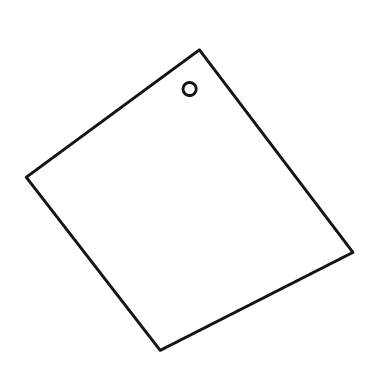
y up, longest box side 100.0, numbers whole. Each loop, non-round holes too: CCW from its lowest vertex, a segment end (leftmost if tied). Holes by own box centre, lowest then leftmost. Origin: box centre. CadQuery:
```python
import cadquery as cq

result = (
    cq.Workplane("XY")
    .moveTo(-9.0, -46.0)
    .lineTo(50.0, -16.0)
    .lineTo(3.0, 46.0)
    .lineTo(-50.0, 7.0)
    .close()
    .moveTo(0.0, 34.0)
    .circle(2.0)
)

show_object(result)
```